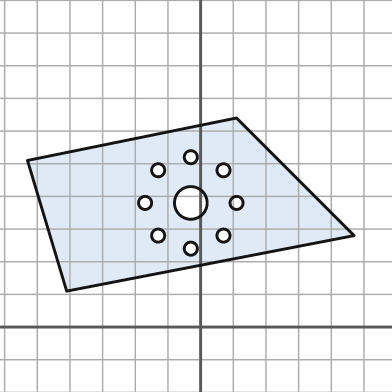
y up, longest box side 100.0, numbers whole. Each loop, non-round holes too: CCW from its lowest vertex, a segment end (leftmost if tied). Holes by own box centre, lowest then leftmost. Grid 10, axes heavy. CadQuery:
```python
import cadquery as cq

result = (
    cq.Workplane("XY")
    .moveTo(-41.0, 11.0)
    .lineTo(47.0, 28.0)
    .lineTo(11.0, 64.0)
    .lineTo(-53.0, 51.0)
    .close()
    .moveTo(-3.0, 24.0)
    .circle(2.0)
    .moveTo(-13.0, 28.0)
    .circle(2.0)
    .moveTo(7.0, 28.0)
    .circle(2.0)
    .moveTo(-17.0, 38.0)
    .circle(2.0)
    .moveTo(-3.0, 38.0)
    .circle(5.0)
    .moveTo(11.0, 38.0)
    .circle(2.0)
    .moveTo(-13.0, 48.0)
    .circle(2.0)
    .moveTo(7.0, 48.0)
    .circle(2.0)
    .moveTo(-3.0, 52.0)
    .circle(2.0)
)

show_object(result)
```